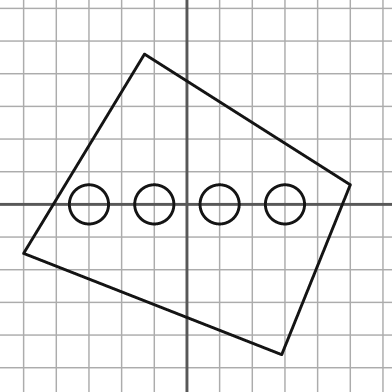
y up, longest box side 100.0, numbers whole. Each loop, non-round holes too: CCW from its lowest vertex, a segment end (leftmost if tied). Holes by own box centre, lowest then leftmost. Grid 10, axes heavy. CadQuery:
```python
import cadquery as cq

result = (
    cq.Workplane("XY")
    .moveTo(29.0, -46.0)
    .lineTo(50.0, 6.0)
    .lineTo(-13.0, 46.0)
    .lineTo(-50.0, -15.0)
    .close()
    .moveTo(-30.0, 0.0)
    .circle(6.0)
    .moveTo(-10.0, 0.0)
    .circle(6.0)
    .moveTo(10.0, 0.0)
    .circle(6.0)
    .moveTo(30.0, 0.0)
    .circle(6.0)
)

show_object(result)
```